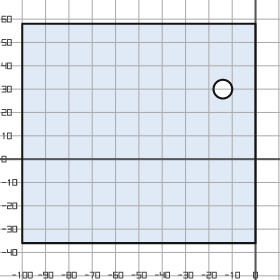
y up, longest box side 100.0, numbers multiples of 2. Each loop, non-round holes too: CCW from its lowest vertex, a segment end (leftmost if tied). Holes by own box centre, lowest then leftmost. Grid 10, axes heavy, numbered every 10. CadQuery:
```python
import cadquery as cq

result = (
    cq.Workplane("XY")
    .moveTo(-100.0, -36.0)
    .lineTo(0.0, -36.0)
    .lineTo(0.0, 58.0)
    .lineTo(-100.0, 58.0)
    .close()
    .moveTo(-14.0, 30.0)
    .circle(4.0)
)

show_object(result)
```